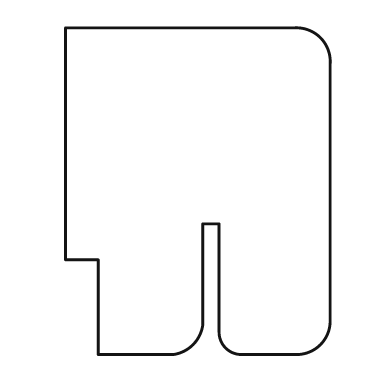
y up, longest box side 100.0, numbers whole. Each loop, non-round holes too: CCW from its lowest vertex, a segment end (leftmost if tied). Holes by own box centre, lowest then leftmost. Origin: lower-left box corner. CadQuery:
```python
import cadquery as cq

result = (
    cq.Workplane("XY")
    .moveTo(10.0, 0.0)
    .lineTo(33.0, 0.0)
    .threePointArc((39.0, 3.0), (42.0, 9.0))
    .lineTo(42.0, 40.0)
    .lineTo(47.0, 40.0)
    .lineTo(47.0, 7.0)
    .threePointArc((49.0, 2.0), (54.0, 0.0))
    .lineTo(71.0, 0.0)
    .threePointArc((78.0, 3.0), (81.0, 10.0))
    .lineTo(81.0, 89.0)
    .threePointArc((78.0, 97.0), (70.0, 100.0))
    .lineTo(0.0, 100.0)
    .lineTo(0.0, 29.0)
    .lineTo(10.0, 29.0)
    .close()
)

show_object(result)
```